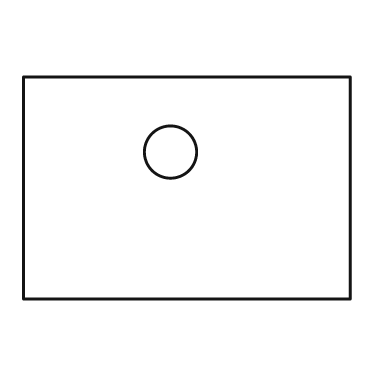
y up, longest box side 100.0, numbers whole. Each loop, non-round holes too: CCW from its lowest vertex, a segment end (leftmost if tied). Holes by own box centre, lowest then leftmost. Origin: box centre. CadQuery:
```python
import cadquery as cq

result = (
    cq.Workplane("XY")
    .moveTo(-50.0, -34.0)
    .lineTo(50.0, -34.0)
    .lineTo(50.0, 34.0)
    .lineTo(-50.0, 34.0)
    .close()
    .moveTo(-5.0, 11.0)
    .circle(8.0)
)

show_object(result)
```